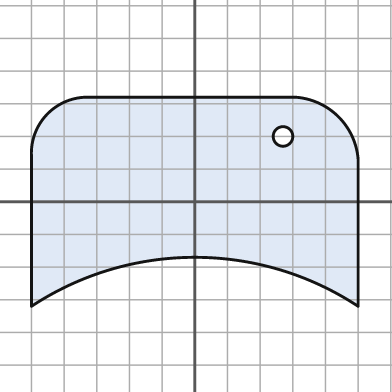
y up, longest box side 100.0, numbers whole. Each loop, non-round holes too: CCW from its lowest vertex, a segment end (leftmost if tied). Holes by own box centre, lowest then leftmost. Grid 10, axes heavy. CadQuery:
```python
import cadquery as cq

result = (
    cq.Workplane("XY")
    .moveTo(-50.0, -32.0)
    .threePointArc((0.0, -17.0), (50.0, -32.0))
    .lineTo(50.0, 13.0)
    .threePointArc((44.0, 26.0), (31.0, 32.0))
    .lineTo(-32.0, 32.0)
    .threePointArc((-45.0, 27.0), (-50.0, 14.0))
    .close()
    .moveTo(27.0, 20.0)
    .circle(3.0)
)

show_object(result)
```